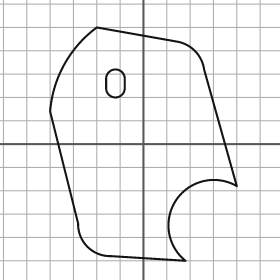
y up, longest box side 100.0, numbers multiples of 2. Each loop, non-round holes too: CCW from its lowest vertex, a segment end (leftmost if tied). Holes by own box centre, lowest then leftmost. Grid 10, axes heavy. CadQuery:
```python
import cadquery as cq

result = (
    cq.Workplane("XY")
    .moveTo(18.0, -50.0)
    .threePointArc((14.0, -24.0), (40.0, -18.0))
    .lineTo(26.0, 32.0)
    .threePointArc((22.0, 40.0), (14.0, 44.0))
    .lineTo(-20.0, 50.0)
    .threePointArc((-34.0, 34.0), (-40.0, 14.0))
    .lineTo(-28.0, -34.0)
    .threePointArc((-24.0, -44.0), (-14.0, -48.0))
    .close()
    .moveTo(-16.0, 24.0)
    .threePointArc((-12.0, 20.0), (-8.0, 24.0))
    .lineTo(-8.0, 28.0)
    .threePointArc((-12.0, 32.0), (-16.0, 28.0))
    .close()
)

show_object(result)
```